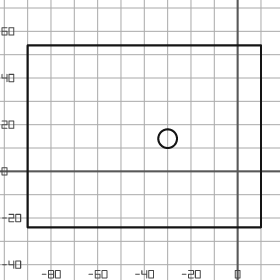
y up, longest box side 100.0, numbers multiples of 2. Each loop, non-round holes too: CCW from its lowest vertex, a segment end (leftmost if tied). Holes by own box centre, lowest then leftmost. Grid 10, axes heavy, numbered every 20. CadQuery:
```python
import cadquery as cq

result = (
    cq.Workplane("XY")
    .moveTo(-90.0, -24.0)
    .lineTo(10.0, -24.0)
    .lineTo(10.0, 54.0)
    .lineTo(-90.0, 54.0)
    .close()
    .moveTo(-30.0, 14.0)
    .circle(4.0)
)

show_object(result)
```